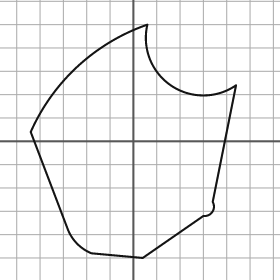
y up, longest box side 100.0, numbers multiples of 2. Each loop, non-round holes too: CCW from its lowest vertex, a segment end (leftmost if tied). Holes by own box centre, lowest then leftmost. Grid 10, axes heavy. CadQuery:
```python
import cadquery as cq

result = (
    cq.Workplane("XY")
    .moveTo(4.0, -50.0)
    .lineTo(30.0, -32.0)
    .threePointArc((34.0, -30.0), (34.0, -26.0))
    .lineTo(44.0, 24.0)
    .threePointArc((16.0, 24.0), (6.0, 50.0))
    .threePointArc((-24.0, 32.0), (-44.0, 4.0))
    .lineTo(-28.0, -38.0)
    .threePointArc((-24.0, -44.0), (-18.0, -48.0))
    .close()
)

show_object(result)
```